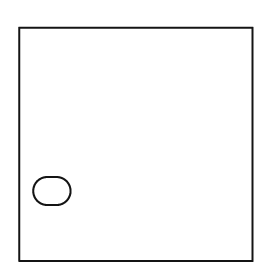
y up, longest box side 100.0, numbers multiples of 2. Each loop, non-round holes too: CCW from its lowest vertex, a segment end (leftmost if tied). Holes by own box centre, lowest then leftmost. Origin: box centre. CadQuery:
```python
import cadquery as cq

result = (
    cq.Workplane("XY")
    .moveTo(-50.0, -50.0)
    .lineTo(50.0, -50.0)
    .lineTo(50.0, 50.0)
    .lineTo(-50.0, 50.0)
    .close()
    .moveTo(-38.0, -26.0)
    .lineTo(-34.0, -26.0)
    .threePointArc((-28.0, -20.0), (-34.0, -14.0))
    .lineTo(-38.0, -14.0)
    .threePointArc((-44.0, -20.0), (-38.0, -26.0))
    .close()
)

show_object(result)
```